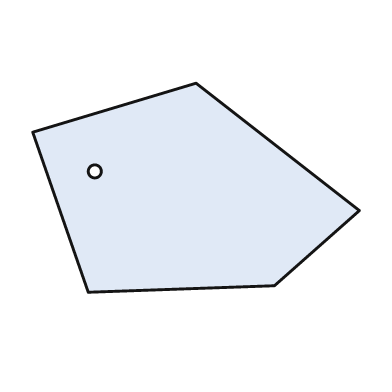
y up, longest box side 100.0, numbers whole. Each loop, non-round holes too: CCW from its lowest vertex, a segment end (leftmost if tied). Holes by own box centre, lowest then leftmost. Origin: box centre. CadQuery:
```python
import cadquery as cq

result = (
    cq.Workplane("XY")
    .moveTo(-33.0, -32.0)
    .lineTo(24.0, -30.0)
    .lineTo(50.0, -7.0)
    .lineTo(0.0, 32.0)
    .lineTo(-50.0, 17.0)
    .close()
    .moveTo(-31.0, 5.0)
    .circle(2.0)
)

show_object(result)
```